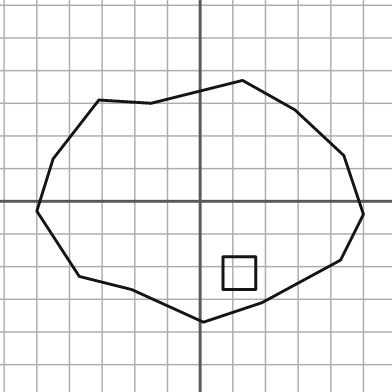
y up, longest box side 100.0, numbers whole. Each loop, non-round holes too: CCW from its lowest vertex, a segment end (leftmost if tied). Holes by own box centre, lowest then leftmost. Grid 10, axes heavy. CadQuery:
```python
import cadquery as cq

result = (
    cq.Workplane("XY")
    .moveTo(1.0, -37.0)
    .lineTo(19.0, -31.0)
    .lineTo(43.0, -18.0)
    .lineTo(50.0, -4.0)
    .lineTo(44.0, 14.0)
    .lineTo(29.0, 28.0)
    .lineTo(13.0, 37.0)
    .lineTo(-15.0, 30.0)
    .lineTo(-31.0, 31.0)
    .lineTo(-45.0, 13.0)
    .lineTo(-50.0, -3.0)
    .lineTo(-37.0, -23.0)
    .lineTo(-21.0, -27.0)
    .close()
    .moveTo(7.0, -27.0)
    .lineTo(17.0, -27.0)
    .lineTo(17.0, -17.0)
    .lineTo(7.0, -17.0)
    .close()
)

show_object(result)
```